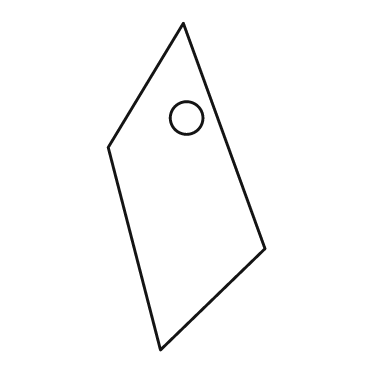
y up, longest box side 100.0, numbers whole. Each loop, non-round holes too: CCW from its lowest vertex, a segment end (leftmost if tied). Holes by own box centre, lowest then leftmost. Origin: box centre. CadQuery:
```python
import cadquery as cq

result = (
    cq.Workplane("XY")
    .moveTo(-8.0, -50.0)
    .lineTo(24.0, -19.0)
    .lineTo(-1.0, 50.0)
    .lineTo(-24.0, 12.0)
    .close()
    .moveTo(0.0, 21.0)
    .circle(5.0)
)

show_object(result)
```